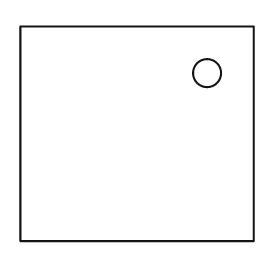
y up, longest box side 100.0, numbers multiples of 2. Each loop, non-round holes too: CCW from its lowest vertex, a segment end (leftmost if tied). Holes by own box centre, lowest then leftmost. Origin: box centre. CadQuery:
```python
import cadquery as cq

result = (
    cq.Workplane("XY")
    .moveTo(-50.0, -46.0)
    .lineTo(50.0, -46.0)
    .lineTo(50.0, 46.0)
    .lineTo(-50.0, 46.0)
    .close()
    .moveTo(30.0, 26.0)
    .circle(6.0)
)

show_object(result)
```